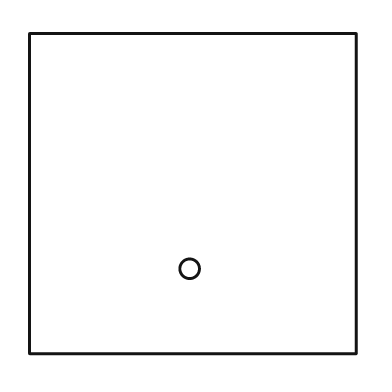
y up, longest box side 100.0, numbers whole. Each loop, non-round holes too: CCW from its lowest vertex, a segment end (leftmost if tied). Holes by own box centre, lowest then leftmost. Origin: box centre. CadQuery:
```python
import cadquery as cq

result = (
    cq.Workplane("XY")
    .moveTo(-50.0, -49.0)
    .lineTo(50.0, -49.0)
    .lineTo(50.0, 49.0)
    .lineTo(-50.0, 49.0)
    .close()
    .moveTo(-1.0, -23.0)
    .circle(3.0)
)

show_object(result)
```